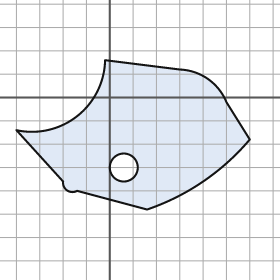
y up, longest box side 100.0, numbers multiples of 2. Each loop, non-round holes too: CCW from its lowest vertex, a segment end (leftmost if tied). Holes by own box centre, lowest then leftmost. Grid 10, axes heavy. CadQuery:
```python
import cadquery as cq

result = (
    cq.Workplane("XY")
    .moveTo(16.0, -48.0)
    .threePointArc((40.0, -36.0), (60.0, -18.0))
    .lineTo(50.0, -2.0)
    .threePointArc((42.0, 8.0), (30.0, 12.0))
    .lineTo(-2.0, 16.0)
    .threePointArc((-14.0, -8.0), (-40.0, -14.0))
    .lineTo(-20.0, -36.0)
    .threePointArc((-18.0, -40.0), (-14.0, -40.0))
    .close()
    .moveTo(6.0, -30.0)
    .circle(6.0)
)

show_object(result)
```